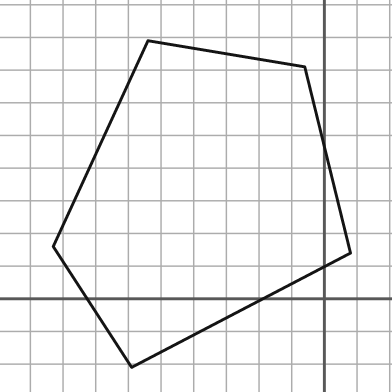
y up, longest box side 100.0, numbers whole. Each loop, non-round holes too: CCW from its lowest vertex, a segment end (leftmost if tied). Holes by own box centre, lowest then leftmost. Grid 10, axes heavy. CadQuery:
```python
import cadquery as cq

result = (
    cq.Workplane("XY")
    .moveTo(-59.0, -21.0)
    .lineTo(8.0, 14.0)
    .lineTo(-6.0, 71.0)
    .lineTo(-54.0, 79.0)
    .lineTo(-83.0, 16.0)
    .close()
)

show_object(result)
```